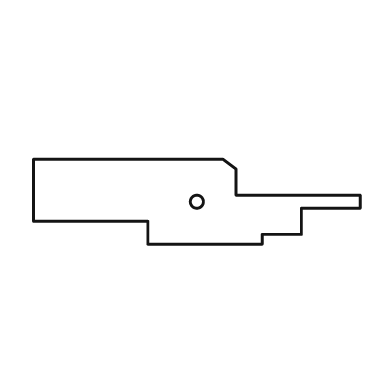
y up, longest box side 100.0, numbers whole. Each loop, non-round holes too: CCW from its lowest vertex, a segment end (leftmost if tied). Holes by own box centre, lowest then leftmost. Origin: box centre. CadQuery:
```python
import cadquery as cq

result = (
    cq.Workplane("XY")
    .moveTo(-15.0, -13.0)
    .lineTo(20.0, -13.0)
    .lineTo(20.0, -10.0)
    .lineTo(32.0, -10.0)
    .lineTo(32.0, -2.0)
    .lineTo(50.0, -2.0)
    .lineTo(50.0, 2.0)
    .lineTo(12.0, 2.0)
    .lineTo(12.0, 10.0)
    .lineTo(8.0, 13.0)
    .lineTo(-50.0, 13.0)
    .lineTo(-50.0, -6.0)
    .lineTo(-15.0, -6.0)
    .close()
    .moveTo(0.0, 0.0)
    .circle(2.0)
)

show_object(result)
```